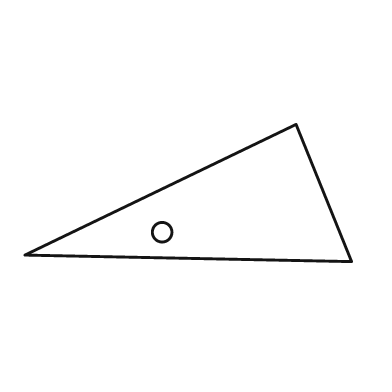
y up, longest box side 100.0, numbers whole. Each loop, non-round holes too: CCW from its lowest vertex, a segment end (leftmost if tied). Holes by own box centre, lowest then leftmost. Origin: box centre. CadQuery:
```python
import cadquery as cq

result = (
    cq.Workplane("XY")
    .moveTo(50.0, -21.0)
    .lineTo(33.0, 21.0)
    .lineTo(-50.0, -19.0)
    .close()
    .moveTo(-8.0, -12.0)
    .circle(3.0)
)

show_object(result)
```